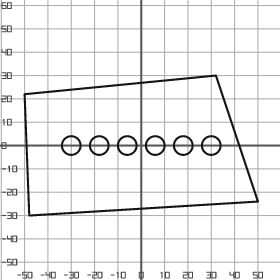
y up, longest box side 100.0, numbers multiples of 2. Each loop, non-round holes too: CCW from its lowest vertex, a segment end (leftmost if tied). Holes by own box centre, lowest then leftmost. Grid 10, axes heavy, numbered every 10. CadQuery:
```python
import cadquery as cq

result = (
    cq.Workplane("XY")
    .moveTo(-48.0, -30.0)
    .lineTo(50.0, -24.0)
    .lineTo(32.0, 30.0)
    .lineTo(-50.0, 22.0)
    .close()
    .moveTo(-30.0, 0.0)
    .circle(4.0)
    .moveTo(-18.0, 0.0)
    .circle(4.0)
    .moveTo(-6.0, 0.0)
    .circle(4.0)
    .moveTo(6.0, 0.0)
    .circle(4.0)
    .moveTo(18.0, 0.0)
    .circle(4.0)
    .moveTo(30.0, 0.0)
    .circle(4.0)
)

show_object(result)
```